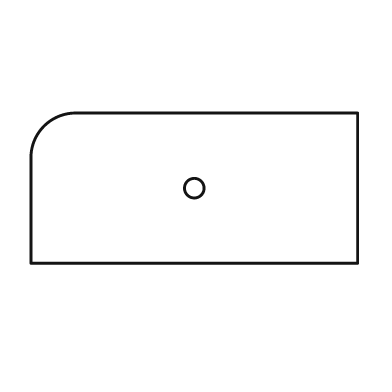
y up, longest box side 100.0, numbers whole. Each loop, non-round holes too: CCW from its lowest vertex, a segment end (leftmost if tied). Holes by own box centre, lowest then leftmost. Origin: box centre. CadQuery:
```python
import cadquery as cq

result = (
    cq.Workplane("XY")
    .moveTo(-50.0, -23.0)
    .lineTo(50.0, -23.0)
    .lineTo(50.0, 23.0)
    .lineTo(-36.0, 23.0)
    .threePointArc((-46.0, 19.0), (-50.0, 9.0))
    .close()
    .moveTo(0.0, 0.0)
    .circle(3.0)
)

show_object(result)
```